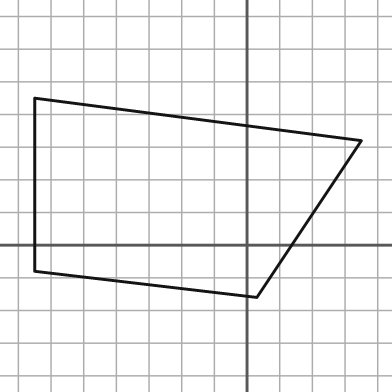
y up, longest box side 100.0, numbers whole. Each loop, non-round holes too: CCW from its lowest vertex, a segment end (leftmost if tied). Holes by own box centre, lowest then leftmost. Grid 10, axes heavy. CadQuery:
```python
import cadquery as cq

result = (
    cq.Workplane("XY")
    .moveTo(3.0, -16.0)
    .lineTo(35.0, 32.0)
    .lineTo(-65.0, 45.0)
    .lineTo(-65.0, -8.0)
    .close()
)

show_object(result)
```